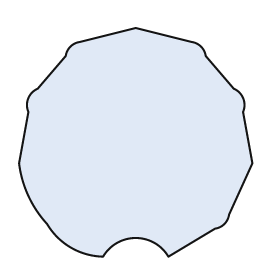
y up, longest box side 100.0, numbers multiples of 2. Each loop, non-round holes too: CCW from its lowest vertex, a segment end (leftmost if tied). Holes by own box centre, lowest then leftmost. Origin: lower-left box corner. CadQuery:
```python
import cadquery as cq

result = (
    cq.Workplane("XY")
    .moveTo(36.0, 0.0)
    .threePointArc((50.0, 8.0), (64.0, 0.0))
    .lineTo(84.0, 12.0)
    .threePointArc((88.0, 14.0), (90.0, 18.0))
    .lineTo(100.0, 40.0)
    .lineTo(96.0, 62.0)
    .threePointArc((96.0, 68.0), (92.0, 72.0))
    .lineTo(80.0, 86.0)
    .threePointArc((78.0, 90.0), (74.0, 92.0))
    .lineTo(50.0, 98.0)
    .lineTo(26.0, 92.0)
    .threePointArc((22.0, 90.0), (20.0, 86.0))
    .lineTo(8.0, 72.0)
    .threePointArc((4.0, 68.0), (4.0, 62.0))
    .lineTo(0.0, 40.0)
    .threePointArc((4.0, 26.0), (12.0, 14.0))
    .threePointArc((22.0, 4.0), (36.0, 0.0))
    .close()
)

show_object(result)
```